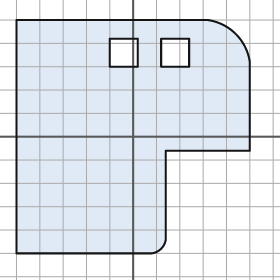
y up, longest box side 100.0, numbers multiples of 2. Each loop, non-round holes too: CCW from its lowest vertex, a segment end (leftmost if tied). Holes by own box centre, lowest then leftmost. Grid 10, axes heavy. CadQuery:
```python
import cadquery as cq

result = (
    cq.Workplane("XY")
    .moveTo(-50.0, -50.0)
    .lineTo(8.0, -50.0)
    .threePointArc((12.0, -48.0), (14.0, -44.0))
    .lineTo(14.0, -6.0)
    .lineTo(50.0, -6.0)
    .lineTo(50.0, 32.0)
    .threePointArc((44.0, 44.0), (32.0, 50.0))
    .lineTo(-50.0, 50.0)
    .close()
    .moveTo(-10.0, 30.0)
    .lineTo(2.0, 30.0)
    .lineTo(2.0, 42.0)
    .lineTo(-10.0, 42.0)
    .close()
    .moveTo(12.0, 30.0)
    .lineTo(24.0, 30.0)
    .lineTo(24.0, 42.0)
    .lineTo(12.0, 42.0)
    .close()
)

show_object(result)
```